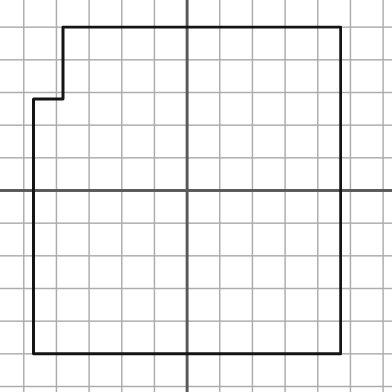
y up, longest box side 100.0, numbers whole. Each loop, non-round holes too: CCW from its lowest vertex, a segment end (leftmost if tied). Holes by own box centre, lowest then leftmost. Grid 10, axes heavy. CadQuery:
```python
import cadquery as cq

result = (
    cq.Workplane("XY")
    .moveTo(-47.0, -50.0)
    .lineTo(47.0, -50.0)
    .lineTo(47.0, 50.0)
    .lineTo(-38.0, 50.0)
    .lineTo(-38.0, 28.0)
    .lineTo(-47.0, 28.0)
    .close()
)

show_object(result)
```